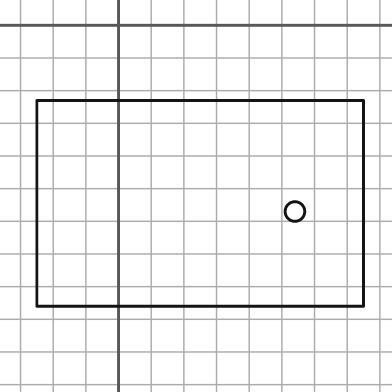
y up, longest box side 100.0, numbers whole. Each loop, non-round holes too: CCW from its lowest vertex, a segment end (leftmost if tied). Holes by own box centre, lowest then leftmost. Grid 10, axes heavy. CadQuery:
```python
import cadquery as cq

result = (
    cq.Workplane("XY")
    .moveTo(-25.0, -86.0)
    .lineTo(75.0, -86.0)
    .lineTo(75.0, -23.0)
    .lineTo(-25.0, -23.0)
    .close()
    .moveTo(54.0, -57.0)
    .circle(3.0)
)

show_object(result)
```